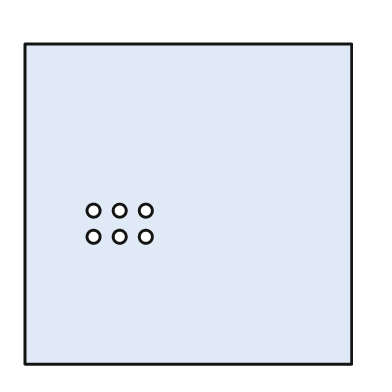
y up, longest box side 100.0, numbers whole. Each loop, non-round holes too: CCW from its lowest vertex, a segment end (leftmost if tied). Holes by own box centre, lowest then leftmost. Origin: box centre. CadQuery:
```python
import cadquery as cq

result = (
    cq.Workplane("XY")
    .moveTo(-50.0, -49.0)
    .lineTo(50.0, -49.0)
    .lineTo(50.0, 49.0)
    .lineTo(-50.0, 49.0)
    .close()
    .moveTo(-29.0, -10.0)
    .circle(2.0)
    .moveTo(-21.0, -10.0)
    .circle(2.0)
    .moveTo(-13.0, -10.0)
    .circle(2.0)
    .moveTo(-29.0, -2.0)
    .circle(2.0)
    .moveTo(-21.0, -2.0)
    .circle(2.0)
    .moveTo(-13.0, -2.0)
    .circle(2.0)
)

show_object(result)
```